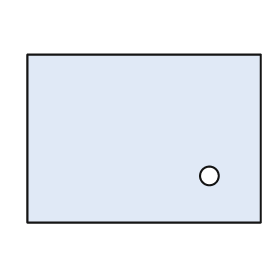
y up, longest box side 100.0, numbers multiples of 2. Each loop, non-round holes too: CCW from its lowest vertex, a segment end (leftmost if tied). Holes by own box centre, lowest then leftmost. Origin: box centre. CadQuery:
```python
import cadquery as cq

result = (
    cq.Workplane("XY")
    .moveTo(-50.0, -36.0)
    .lineTo(50.0, -36.0)
    .lineTo(50.0, 36.0)
    .lineTo(-50.0, 36.0)
    .close()
    .moveTo(28.0, -16.0)
    .circle(4.0)
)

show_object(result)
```